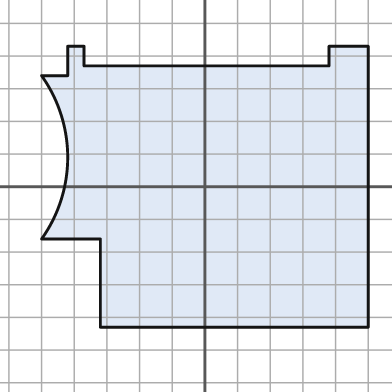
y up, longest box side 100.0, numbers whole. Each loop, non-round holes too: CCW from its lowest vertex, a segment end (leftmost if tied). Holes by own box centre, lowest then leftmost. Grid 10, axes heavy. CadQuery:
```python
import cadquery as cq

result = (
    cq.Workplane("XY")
    .moveTo(-32.0, -43.0)
    .lineTo(50.0, -43.0)
    .lineTo(50.0, 43.0)
    .lineTo(38.0, 43.0)
    .lineTo(38.0, 37.0)
    .lineTo(-37.0, 37.0)
    .lineTo(-37.0, 43.0)
    .lineTo(-42.0, 43.0)
    .lineTo(-42.0, 34.0)
    .lineTo(-50.0, 34.0)
    .threePointArc((-42.0, 9.0), (-50.0, -16.0))
    .lineTo(-32.0, -16.0)
    .close()
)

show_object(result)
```